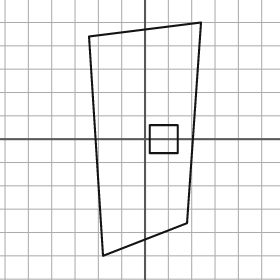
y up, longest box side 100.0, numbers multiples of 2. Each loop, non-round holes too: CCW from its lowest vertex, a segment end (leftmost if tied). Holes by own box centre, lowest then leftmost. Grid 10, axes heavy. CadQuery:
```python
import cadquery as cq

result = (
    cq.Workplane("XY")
    .moveTo(-18.0, -50.0)
    .lineTo(18.0, -36.0)
    .lineTo(24.0, 50.0)
    .lineTo(-24.0, 44.0)
    .close()
    .moveTo(2.0, -6.0)
    .lineTo(14.0, -6.0)
    .lineTo(14.0, 6.0)
    .lineTo(2.0, 6.0)
    .close()
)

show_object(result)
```